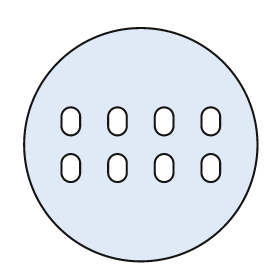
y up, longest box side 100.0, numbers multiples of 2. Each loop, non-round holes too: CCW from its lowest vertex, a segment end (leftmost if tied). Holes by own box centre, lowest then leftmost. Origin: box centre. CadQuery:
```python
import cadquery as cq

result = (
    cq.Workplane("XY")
    .moveTo(0.0, 0.0)
    .circle(50.0)
    .moveTo(-34.0, -12.0)
    .threePointArc((-30.0, -16.0), (-26.0, -12.0))
    .lineTo(-26.0, -8.0)
    .threePointArc((-30.0, -4.0), (-34.0, -8.0))
    .close()
    .moveTo(-14.0, -12.0)
    .threePointArc((-10.0, -16.0), (-6.0, -12.0))
    .lineTo(-6.0, -8.0)
    .threePointArc((-10.0, -4.0), (-14.0, -8.0))
    .close()
    .moveTo(6.0, -12.0)
    .threePointArc((10.0, -16.0), (14.0, -12.0))
    .lineTo(14.0, -8.0)
    .threePointArc((10.0, -4.0), (6.0, -8.0))
    .close()
    .moveTo(26.0, -12.0)
    .threePointArc((30.0, -16.0), (34.0, -12.0))
    .lineTo(34.0, -8.0)
    .threePointArc((30.0, -4.0), (26.0, -8.0))
    .close()
    .moveTo(-34.0, 8.0)
    .threePointArc((-30.0, 4.0), (-26.0, 8.0))
    .lineTo(-26.0, 12.0)
    .threePointArc((-30.0, 16.0), (-34.0, 12.0))
    .close()
    .moveTo(-14.0, 8.0)
    .threePointArc((-10.0, 4.0), (-6.0, 8.0))
    .lineTo(-6.0, 12.0)
    .threePointArc((-10.0, 16.0), (-14.0, 12.0))
    .close()
    .moveTo(6.0, 8.0)
    .threePointArc((10.0, 4.0), (14.0, 8.0))
    .lineTo(14.0, 12.0)
    .threePointArc((10.0, 16.0), (6.0, 12.0))
    .close()
    .moveTo(26.0, 8.0)
    .threePointArc((30.0, 4.0), (34.0, 8.0))
    .lineTo(34.0, 12.0)
    .threePointArc((30.0, 16.0), (26.0, 12.0))
    .close()
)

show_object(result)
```